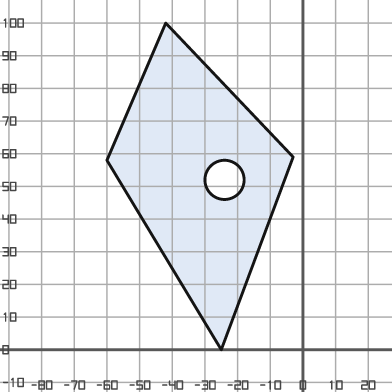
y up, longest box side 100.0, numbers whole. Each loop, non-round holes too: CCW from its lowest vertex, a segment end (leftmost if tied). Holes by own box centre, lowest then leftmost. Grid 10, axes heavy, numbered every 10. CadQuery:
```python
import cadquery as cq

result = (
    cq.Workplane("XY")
    .moveTo(-25.0, 0.0)
    .lineTo(-3.0, 59.0)
    .lineTo(-42.0, 100.0)
    .lineTo(-60.0, 58.0)
    .close()
    .moveTo(-24.0, 52.0)
    .circle(6.0)
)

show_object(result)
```